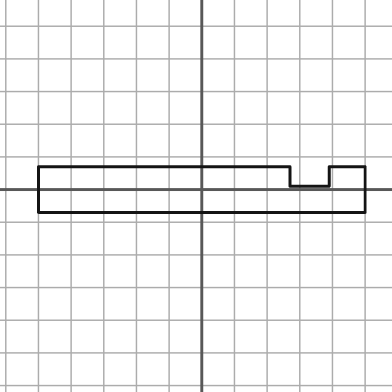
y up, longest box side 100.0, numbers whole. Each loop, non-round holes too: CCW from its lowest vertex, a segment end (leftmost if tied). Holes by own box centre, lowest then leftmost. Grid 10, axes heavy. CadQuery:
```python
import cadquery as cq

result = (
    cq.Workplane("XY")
    .moveTo(-50.0, -7.0)
    .lineTo(50.0, -7.0)
    .lineTo(50.0, 7.0)
    .lineTo(39.0, 7.0)
    .lineTo(39.0, 1.0)
    .lineTo(27.0, 1.0)
    .lineTo(27.0, 7.0)
    .lineTo(-50.0, 7.0)
    .close()
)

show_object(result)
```